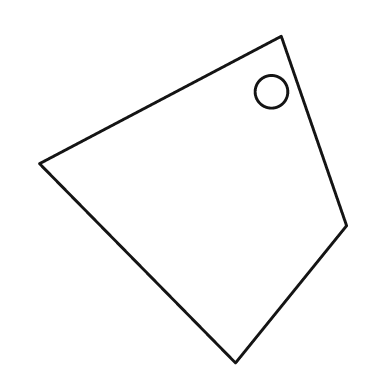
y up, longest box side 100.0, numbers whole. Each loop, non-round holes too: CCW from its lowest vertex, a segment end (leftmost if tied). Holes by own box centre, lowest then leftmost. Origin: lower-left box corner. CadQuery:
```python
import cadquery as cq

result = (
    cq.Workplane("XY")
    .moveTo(60.0, 0.0)
    .lineTo(94.0, 42.0)
    .lineTo(74.0, 100.0)
    .lineTo(0.0, 61.0)
    .close()
    .moveTo(71.0, 83.0)
    .circle(5.0)
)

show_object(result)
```